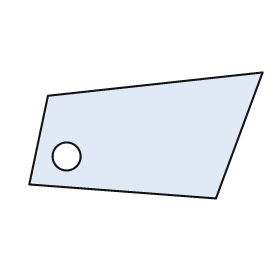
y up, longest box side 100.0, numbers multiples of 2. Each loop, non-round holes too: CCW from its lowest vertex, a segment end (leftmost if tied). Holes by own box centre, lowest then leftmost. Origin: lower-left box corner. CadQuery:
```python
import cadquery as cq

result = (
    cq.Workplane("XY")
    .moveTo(80.0, 0.0)
    .lineTo(100.0, 54.0)
    .lineTo(8.0, 44.0)
    .lineTo(0.0, 6.0)
    .close()
    .moveTo(16.0, 18.0)
    .circle(6.0)
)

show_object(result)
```